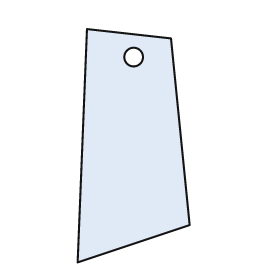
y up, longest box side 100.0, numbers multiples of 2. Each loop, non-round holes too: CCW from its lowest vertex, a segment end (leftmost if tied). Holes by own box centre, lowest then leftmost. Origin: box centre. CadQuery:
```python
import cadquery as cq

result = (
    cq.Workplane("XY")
    .moveTo(-24.0, -50.0)
    .lineTo(24.0, -34.0)
    .lineTo(16.0, 46.0)
    .lineTo(-20.0, 50.0)
    .close()
    .moveTo(0.0, 38.0)
    .circle(4.0)
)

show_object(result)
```